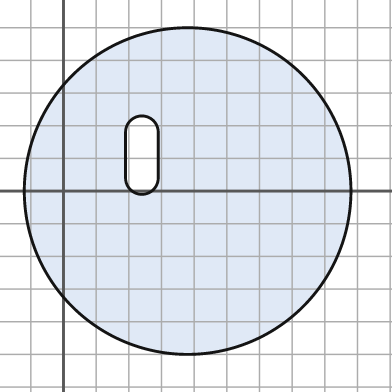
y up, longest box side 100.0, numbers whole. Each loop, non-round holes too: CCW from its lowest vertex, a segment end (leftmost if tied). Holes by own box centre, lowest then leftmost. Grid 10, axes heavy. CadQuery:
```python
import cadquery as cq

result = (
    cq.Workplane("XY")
    .moveTo(38.0, 0.0)
    .circle(50.0)
    .moveTo(19.0, 4.0)
    .threePointArc((24.0, -1.0), (29.0, 4.0))
    .lineTo(29.0, 18.0)
    .threePointArc((24.0, 23.0), (19.0, 18.0))
    .close()
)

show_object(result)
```